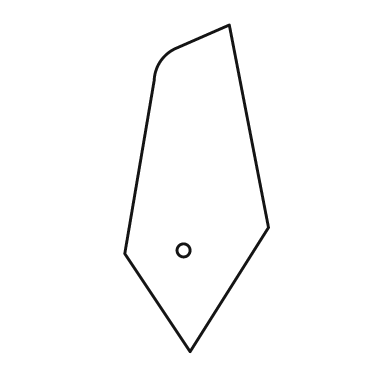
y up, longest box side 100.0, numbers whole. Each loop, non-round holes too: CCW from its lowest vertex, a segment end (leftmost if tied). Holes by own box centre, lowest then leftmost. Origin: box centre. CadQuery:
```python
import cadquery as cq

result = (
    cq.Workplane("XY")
    .moveTo(-2.0, -50.0)
    .lineTo(22.0, -12.0)
    .lineTo(10.0, 50.0)
    .lineTo(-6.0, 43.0)
    .threePointArc((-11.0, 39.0), (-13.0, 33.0))
    .lineTo(-22.0, -20.0)
    .close()
    .moveTo(-4.0, -19.0)
    .circle(2.0)
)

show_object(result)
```